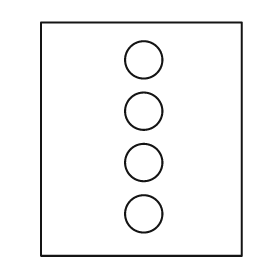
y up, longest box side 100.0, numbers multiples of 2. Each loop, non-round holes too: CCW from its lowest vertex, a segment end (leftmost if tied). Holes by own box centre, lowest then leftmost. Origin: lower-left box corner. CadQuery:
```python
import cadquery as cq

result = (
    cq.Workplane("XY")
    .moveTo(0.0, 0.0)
    .lineTo(86.0, 0.0)
    .lineTo(86.0, 100.0)
    .lineTo(0.0, 100.0)
    .close()
    .moveTo(44.0, 18.0)
    .circle(8.0)
    .moveTo(44.0, 40.0)
    .circle(8.0)
    .moveTo(44.0, 62.0)
    .circle(8.0)
    .moveTo(44.0, 84.0)
    .circle(8.0)
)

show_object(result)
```